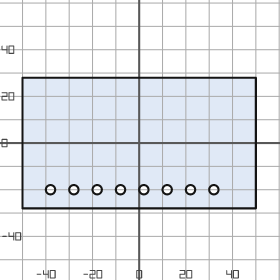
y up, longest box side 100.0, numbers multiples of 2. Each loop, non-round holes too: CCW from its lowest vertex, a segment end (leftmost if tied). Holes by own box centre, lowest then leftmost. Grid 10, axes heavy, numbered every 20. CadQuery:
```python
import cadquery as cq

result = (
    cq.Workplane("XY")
    .moveTo(-50.0, -28.0)
    .lineTo(50.0, -28.0)
    .lineTo(50.0, 28.0)
    .lineTo(-50.0, 28.0)
    .close()
    .moveTo(-38.0, -20.0)
    .circle(2.0)
    .moveTo(-28.0, -20.0)
    .circle(2.0)
    .moveTo(-18.0, -20.0)
    .circle(2.0)
    .moveTo(-8.0, -20.0)
    .circle(2.0)
    .moveTo(2.0, -20.0)
    .circle(2.0)
    .moveTo(12.0, -20.0)
    .circle(2.0)
    .moveTo(22.0, -20.0)
    .circle(2.0)
    .moveTo(32.0, -20.0)
    .circle(2.0)
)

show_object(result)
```